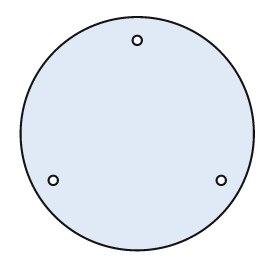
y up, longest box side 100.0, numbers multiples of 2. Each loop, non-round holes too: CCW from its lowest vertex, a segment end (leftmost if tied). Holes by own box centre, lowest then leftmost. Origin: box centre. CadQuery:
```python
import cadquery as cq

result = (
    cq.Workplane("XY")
    .moveTo(0.0, 0.0)
    .circle(50.0)
    .moveTo(-36.0, -20.0)
    .circle(2.0)
    .moveTo(36.0, -20.0)
    .circle(2.0)
    .moveTo(0.0, 40.0)
    .circle(2.0)
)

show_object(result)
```